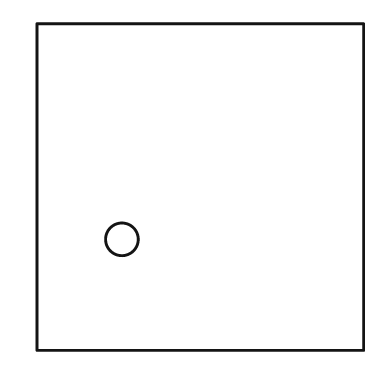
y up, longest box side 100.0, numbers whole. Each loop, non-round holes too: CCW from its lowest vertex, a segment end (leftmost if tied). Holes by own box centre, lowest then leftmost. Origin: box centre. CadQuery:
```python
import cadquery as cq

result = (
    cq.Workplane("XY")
    .moveTo(-50.0, -50.0)
    .lineTo(50.0, -50.0)
    .lineTo(50.0, 50.0)
    .lineTo(-50.0, 50.0)
    .close()
    .moveTo(-24.0, -16.0)
    .circle(5.0)
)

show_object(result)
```